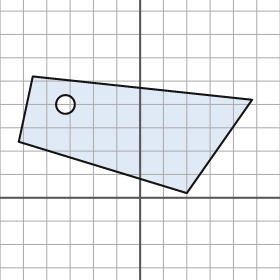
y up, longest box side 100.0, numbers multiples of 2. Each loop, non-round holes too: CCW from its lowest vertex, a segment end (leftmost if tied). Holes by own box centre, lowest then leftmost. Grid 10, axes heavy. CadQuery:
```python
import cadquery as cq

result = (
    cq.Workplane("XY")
    .moveTo(20.0, 2.0)
    .lineTo(48.0, 42.0)
    .lineTo(-46.0, 52.0)
    .lineTo(-52.0, 24.0)
    .close()
    .moveTo(-32.0, 40.0)
    .circle(4.0)
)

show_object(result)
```